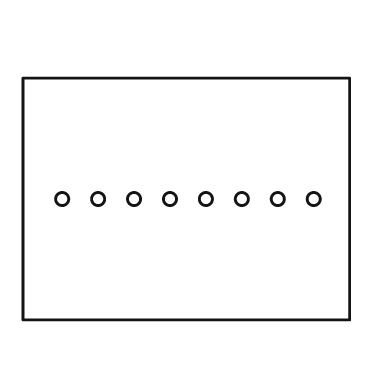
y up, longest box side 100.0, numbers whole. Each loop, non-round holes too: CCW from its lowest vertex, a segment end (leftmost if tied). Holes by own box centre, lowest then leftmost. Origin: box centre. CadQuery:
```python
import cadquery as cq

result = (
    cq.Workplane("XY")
    .moveTo(-50.0, -37.0)
    .lineTo(50.0, -37.0)
    .lineTo(50.0, 37.0)
    .lineTo(-50.0, 37.0)
    .close()
    .moveTo(-38.0, 0.0)
    .circle(2.0)
    .moveTo(-27.0, 0.0)
    .circle(2.0)
    .moveTo(-16.0, 0.0)
    .circle(2.0)
    .moveTo(-5.0, 0.0)
    .circle(2.0)
    .moveTo(6.0, 0.0)
    .circle(2.0)
    .moveTo(17.0, 0.0)
    .circle(2.0)
    .moveTo(28.0, 0.0)
    .circle(2.0)
    .moveTo(39.0, 0.0)
    .circle(2.0)
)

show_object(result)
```